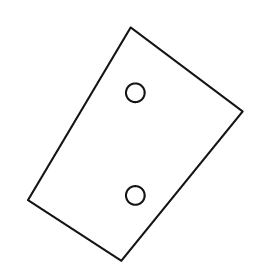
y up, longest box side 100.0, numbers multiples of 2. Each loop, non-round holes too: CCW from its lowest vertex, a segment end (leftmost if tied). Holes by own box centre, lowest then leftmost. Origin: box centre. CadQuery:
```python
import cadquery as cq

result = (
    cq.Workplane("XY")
    .moveTo(-6.0, -50.0)
    .lineTo(46.0, 14.0)
    .lineTo(-2.0, 50.0)
    .lineTo(-46.0, -24.0)
    .close()
    .moveTo(0.0, -22.0)
    .circle(4.0)
    .moveTo(0.0, 22.0)
    .circle(4.0)
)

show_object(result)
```